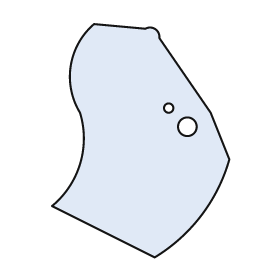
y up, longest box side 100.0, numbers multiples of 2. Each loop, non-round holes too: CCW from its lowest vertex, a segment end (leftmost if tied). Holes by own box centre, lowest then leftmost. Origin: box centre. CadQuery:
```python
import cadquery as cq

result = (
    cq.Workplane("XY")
    .moveTo(6.0, -50.0)
    .threePointArc((26.0, -32.0), (38.0, -8.0))
    .lineTo(30.0, 12.0)
    .lineTo(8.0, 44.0)
    .threePointArc((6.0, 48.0), (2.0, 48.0))
    .lineTo(-20.0, 50.0)
    .threePointArc((-30.0, 32.0), (-26.0, 12.0))
    .threePointArc((-26.0, -10.0), (-38.0, -28.0))
    .close()
    .moveTo(20.0, 6.0)
    .circle(4.0)
    .moveTo(12.0, 14.0)
    .circle(2.0)
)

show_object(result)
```